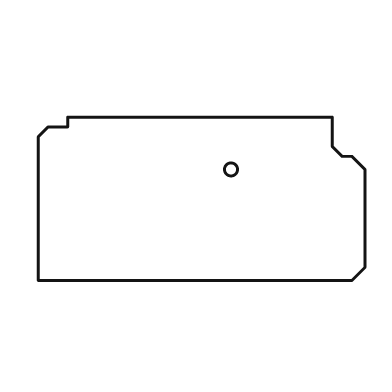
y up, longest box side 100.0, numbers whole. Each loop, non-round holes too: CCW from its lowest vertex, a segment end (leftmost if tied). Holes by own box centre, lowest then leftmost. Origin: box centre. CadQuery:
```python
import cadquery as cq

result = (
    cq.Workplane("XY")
    .moveTo(-50.0, -25.0)
    .lineTo(46.0, -25.0)
    .lineTo(50.0, -21.0)
    .lineTo(50.0, 9.0)
    .lineTo(46.0, 13.0)
    .lineTo(43.0, 13.0)
    .lineTo(40.0, 16.0)
    .lineTo(40.0, 25.0)
    .lineTo(-41.0, 25.0)
    .lineTo(-41.0, 22.0)
    .lineTo(-47.0, 22.0)
    .lineTo(-50.0, 19.0)
    .close()
    .moveTo(9.0, 9.0)
    .circle(2.0)
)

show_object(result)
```